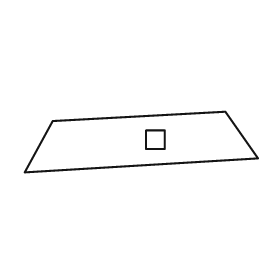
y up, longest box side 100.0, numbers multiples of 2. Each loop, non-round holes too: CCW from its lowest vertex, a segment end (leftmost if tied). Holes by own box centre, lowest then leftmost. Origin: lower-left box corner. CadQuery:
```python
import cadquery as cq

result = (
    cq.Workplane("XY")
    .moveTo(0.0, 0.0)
    .lineTo(100.0, 6.0)
    .lineTo(86.0, 26.0)
    .lineTo(12.0, 22.0)
    .close()
    .moveTo(52.0, 10.0)
    .lineTo(60.0, 10.0)
    .lineTo(60.0, 18.0)
    .lineTo(52.0, 18.0)
    .close()
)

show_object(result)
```